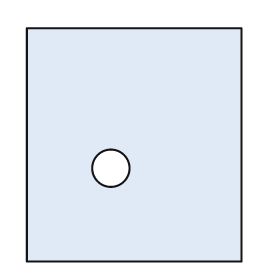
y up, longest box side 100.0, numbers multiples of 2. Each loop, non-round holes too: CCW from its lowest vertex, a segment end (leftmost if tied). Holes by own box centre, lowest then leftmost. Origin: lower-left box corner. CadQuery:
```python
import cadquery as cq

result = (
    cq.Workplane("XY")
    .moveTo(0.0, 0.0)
    .lineTo(92.0, 0.0)
    .lineTo(92.0, 100.0)
    .lineTo(0.0, 100.0)
    .close()
    .moveTo(36.0, 40.0)
    .circle(8.0)
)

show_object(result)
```